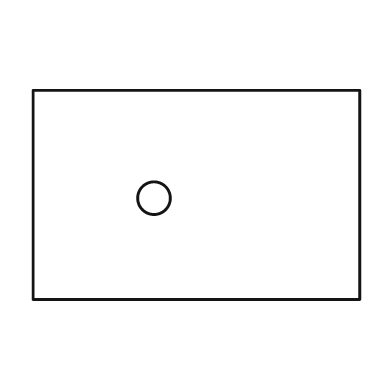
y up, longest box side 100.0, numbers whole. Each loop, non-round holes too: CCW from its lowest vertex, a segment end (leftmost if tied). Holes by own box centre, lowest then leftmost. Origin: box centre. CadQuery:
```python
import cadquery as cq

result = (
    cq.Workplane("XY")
    .moveTo(-50.0, -32.0)
    .lineTo(50.0, -32.0)
    .lineTo(50.0, 32.0)
    .lineTo(-50.0, 32.0)
    .close()
    .moveTo(-13.0, -1.0)
    .circle(5.0)
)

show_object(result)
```